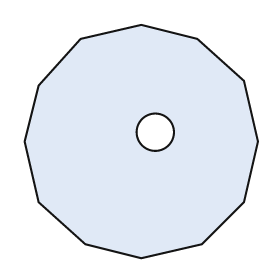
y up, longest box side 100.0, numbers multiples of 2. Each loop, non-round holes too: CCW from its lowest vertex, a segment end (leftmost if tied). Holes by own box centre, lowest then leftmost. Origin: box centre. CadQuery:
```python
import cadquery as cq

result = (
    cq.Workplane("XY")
    .moveTo(0.0, -50.0)
    .lineTo(26.0, -44.0)
    .lineTo(44.0, -26.0)
    .lineTo(50.0, 0.0)
    .lineTo(44.0, 26.0)
    .lineTo(24.0, 44.0)
    .lineTo(0.0, 50.0)
    .lineTo(-26.0, 44.0)
    .lineTo(-44.0, 24.0)
    .lineTo(-50.0, 0.0)
    .lineTo(-44.0, -26.0)
    .lineTo(-24.0, -44.0)
    .close()
    .moveTo(6.0, 4.0)
    .circle(8.0)
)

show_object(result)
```